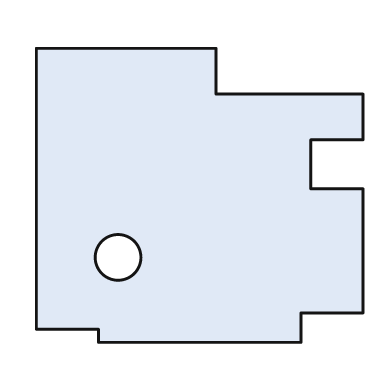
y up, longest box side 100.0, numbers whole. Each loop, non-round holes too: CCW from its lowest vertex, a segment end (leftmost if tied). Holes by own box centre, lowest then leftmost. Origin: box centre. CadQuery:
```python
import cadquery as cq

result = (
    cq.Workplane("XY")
    .moveTo(-31.0, -45.0)
    .lineTo(31.0, -45.0)
    .lineTo(31.0, -36.0)
    .lineTo(50.0, -36.0)
    .lineTo(50.0, 2.0)
    .lineTo(34.0, 2.0)
    .lineTo(34.0, 17.0)
    .lineTo(50.0, 17.0)
    .lineTo(50.0, 31.0)
    .lineTo(5.0, 31.0)
    .lineTo(5.0, 45.0)
    .lineTo(-50.0, 45.0)
    .lineTo(-50.0, -41.0)
    .lineTo(-31.0, -41.0)
    .close()
    .moveTo(-25.0, -19.0)
    .circle(7.0)
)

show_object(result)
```